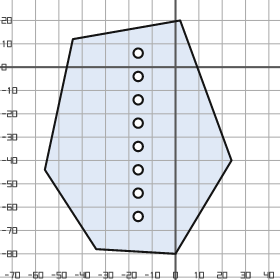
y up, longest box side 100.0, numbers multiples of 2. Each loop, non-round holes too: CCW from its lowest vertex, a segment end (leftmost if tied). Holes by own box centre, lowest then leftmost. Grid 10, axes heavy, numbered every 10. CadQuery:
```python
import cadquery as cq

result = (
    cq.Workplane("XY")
    .moveTo(0.0, -80.0)
    .lineTo(24.0, -40.0)
    .lineTo(2.0, 20.0)
    .lineTo(-44.0, 12.0)
    .lineTo(-56.0, -44.0)
    .lineTo(-34.0, -78.0)
    .close()
    .moveTo(-16.0, -64.0)
    .circle(2.0)
    .moveTo(-16.0, -54.0)
    .circle(2.0)
    .moveTo(-16.0, -44.0)
    .circle(2.0)
    .moveTo(-16.0, -34.0)
    .circle(2.0)
    .moveTo(-16.0, -24.0)
    .circle(2.0)
    .moveTo(-16.0, -14.0)
    .circle(2.0)
    .moveTo(-16.0, -4.0)
    .circle(2.0)
    .moveTo(-16.0, 6.0)
    .circle(2.0)
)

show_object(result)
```